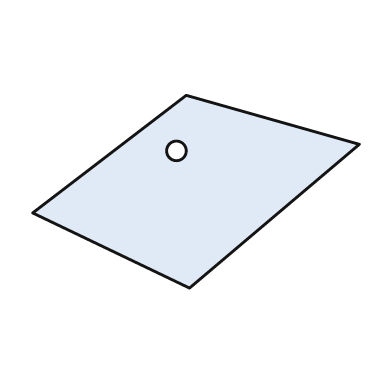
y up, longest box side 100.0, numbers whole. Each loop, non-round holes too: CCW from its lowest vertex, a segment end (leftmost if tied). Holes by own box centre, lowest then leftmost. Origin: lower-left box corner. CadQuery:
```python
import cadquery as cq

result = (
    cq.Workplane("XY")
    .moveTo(48.0, 0.0)
    .lineTo(100.0, 44.0)
    .lineTo(47.0, 59.0)
    .lineTo(0.0, 23.0)
    .close()
    .moveTo(44.0, 42.0)
    .circle(3.0)
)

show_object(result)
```